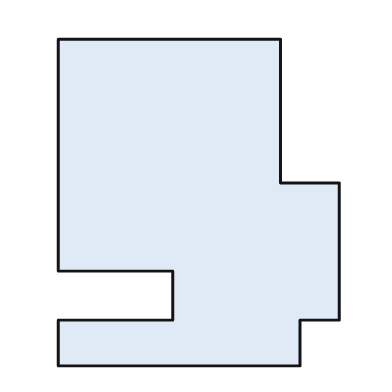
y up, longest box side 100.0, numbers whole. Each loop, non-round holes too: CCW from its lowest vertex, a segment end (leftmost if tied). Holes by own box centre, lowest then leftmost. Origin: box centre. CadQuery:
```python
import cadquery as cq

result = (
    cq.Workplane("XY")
    .moveTo(-43.0, -50.0)
    .lineTo(31.0, -50.0)
    .lineTo(31.0, -36.0)
    .lineTo(43.0, -36.0)
    .lineTo(43.0, 6.0)
    .lineTo(25.0, 6.0)
    .lineTo(25.0, 50.0)
    .lineTo(-43.0, 50.0)
    .lineTo(-43.0, -21.0)
    .lineTo(-8.0, -21.0)
    .lineTo(-8.0, -36.0)
    .lineTo(-43.0, -36.0)
    .close()
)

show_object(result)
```